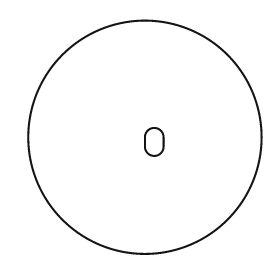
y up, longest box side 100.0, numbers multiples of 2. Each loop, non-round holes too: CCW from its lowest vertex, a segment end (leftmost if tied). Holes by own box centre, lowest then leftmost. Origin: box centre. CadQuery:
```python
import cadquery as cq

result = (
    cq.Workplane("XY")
    .moveTo(0.0, 0.0)
    .circle(50.0)
    .moveTo(0.0, -4.0)
    .threePointArc((4.0, -8.0), (8.0, -4.0))
    .lineTo(8.0, 0.0)
    .threePointArc((4.0, 4.0), (0.0, 0.0))
    .close()
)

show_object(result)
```